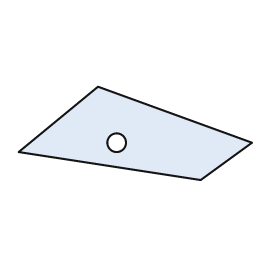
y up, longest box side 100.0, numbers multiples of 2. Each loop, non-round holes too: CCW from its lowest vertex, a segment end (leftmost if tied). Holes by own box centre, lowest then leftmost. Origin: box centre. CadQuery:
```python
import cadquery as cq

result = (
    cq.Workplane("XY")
    .moveTo(28.0, -20.0)
    .lineTo(50.0, -4.0)
    .lineTo(-16.0, 20.0)
    .lineTo(-50.0, -8.0)
    .close()
    .moveTo(-8.0, -4.0)
    .circle(4.0)
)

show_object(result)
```